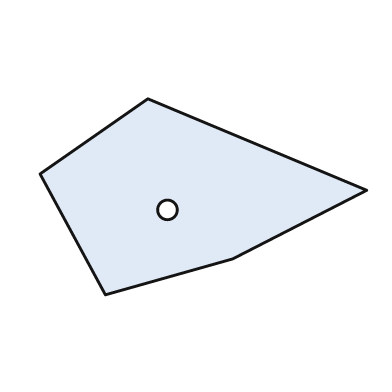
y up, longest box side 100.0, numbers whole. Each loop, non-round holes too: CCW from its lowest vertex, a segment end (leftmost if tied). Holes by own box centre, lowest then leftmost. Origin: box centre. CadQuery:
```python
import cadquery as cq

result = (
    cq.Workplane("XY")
    .moveTo(-30.0, -30.0)
    .lineTo(9.0, -19.0)
    .lineTo(50.0, 2.0)
    .lineTo(-17.0, 30.0)
    .lineTo(-50.0, 7.0)
    .close()
    .moveTo(-11.0, -4.0)
    .circle(3.0)
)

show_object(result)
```